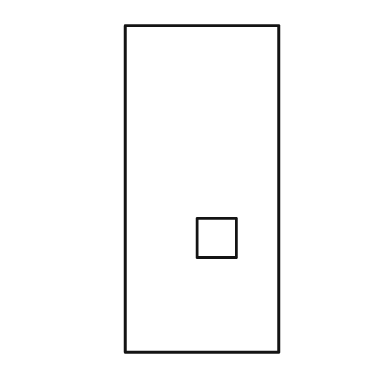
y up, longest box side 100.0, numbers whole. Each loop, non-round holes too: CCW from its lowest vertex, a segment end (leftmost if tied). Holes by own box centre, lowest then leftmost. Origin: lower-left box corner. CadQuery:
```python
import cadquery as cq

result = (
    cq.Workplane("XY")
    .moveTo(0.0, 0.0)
    .lineTo(47.0, 0.0)
    .lineTo(47.0, 100.0)
    .lineTo(0.0, 100.0)
    .close()
    .moveTo(22.0, 29.0)
    .lineTo(34.0, 29.0)
    .lineTo(34.0, 41.0)
    .lineTo(22.0, 41.0)
    .close()
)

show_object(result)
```